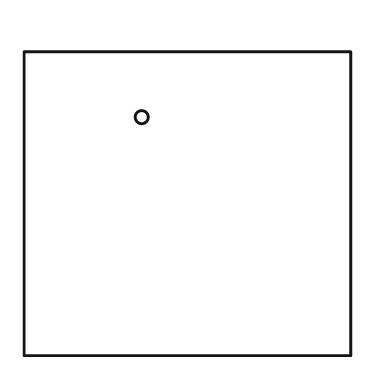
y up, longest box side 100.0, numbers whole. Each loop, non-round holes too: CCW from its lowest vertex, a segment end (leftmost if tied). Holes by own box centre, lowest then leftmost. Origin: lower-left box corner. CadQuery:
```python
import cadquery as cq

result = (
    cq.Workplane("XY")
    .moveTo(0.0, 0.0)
    .lineTo(100.0, 0.0)
    .lineTo(100.0, 93.0)
    .lineTo(0.0, 93.0)
    .close()
    .moveTo(36.0, 73.0)
    .circle(2.0)
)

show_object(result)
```